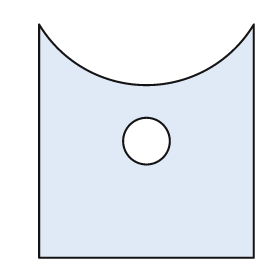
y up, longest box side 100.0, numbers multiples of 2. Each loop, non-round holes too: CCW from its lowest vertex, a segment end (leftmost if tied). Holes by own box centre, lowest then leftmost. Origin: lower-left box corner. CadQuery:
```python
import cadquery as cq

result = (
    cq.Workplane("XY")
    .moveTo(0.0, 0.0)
    .lineTo(92.0, 0.0)
    .lineTo(92.0, 100.0)
    .threePointArc((46.0, 74.0), (0.0, 100.0))
    .close()
    .moveTo(46.0, 50.0)
    .circle(10.0)
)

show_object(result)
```